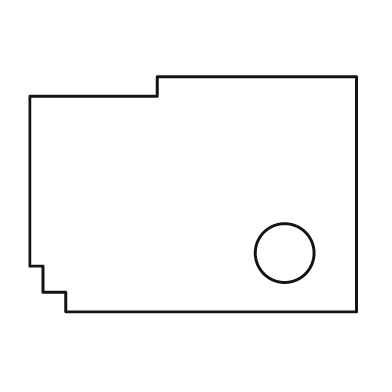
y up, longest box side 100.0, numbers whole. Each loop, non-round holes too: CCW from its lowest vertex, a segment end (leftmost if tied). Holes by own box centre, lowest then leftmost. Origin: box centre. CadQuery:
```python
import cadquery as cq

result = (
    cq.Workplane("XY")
    .moveTo(-39.0, -36.0)
    .lineTo(50.0, -36.0)
    .lineTo(50.0, 36.0)
    .lineTo(-11.0, 36.0)
    .lineTo(-11.0, 30.0)
    .lineTo(-50.0, 30.0)
    .lineTo(-50.0, -22.0)
    .lineTo(-46.0, -22.0)
    .lineTo(-46.0, -30.0)
    .lineTo(-39.0, -30.0)
    .close()
    .moveTo(28.0, -18.0)
    .circle(9.0)
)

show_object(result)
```